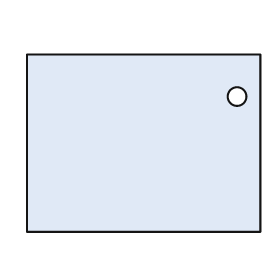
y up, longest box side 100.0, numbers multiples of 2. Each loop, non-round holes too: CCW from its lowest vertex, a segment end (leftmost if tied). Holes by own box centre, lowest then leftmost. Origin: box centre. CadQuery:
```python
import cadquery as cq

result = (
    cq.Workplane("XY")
    .moveTo(-50.0, -38.0)
    .lineTo(50.0, -38.0)
    .lineTo(50.0, 38.0)
    .lineTo(-50.0, 38.0)
    .close()
    .moveTo(40.0, 20.0)
    .circle(4.0)
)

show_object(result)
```